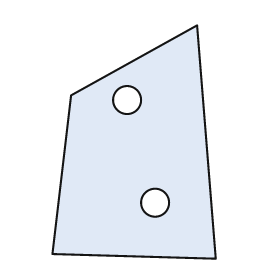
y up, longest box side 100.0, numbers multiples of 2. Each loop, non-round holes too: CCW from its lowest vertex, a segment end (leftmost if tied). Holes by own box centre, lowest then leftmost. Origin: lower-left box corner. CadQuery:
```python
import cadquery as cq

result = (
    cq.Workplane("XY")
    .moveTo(70.0, 0.0)
    .lineTo(62.0, 100.0)
    .lineTo(8.0, 70.0)
    .lineTo(0.0, 2.0)
    .close()
    .moveTo(44.0, 24.0)
    .circle(6.0)
    .moveTo(32.0, 68.0)
    .circle(6.0)
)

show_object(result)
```